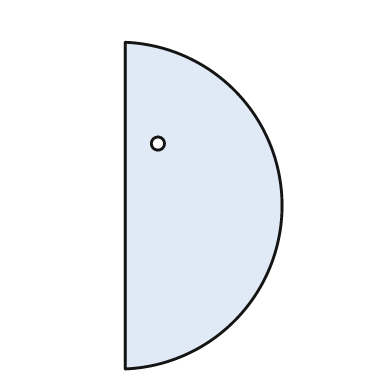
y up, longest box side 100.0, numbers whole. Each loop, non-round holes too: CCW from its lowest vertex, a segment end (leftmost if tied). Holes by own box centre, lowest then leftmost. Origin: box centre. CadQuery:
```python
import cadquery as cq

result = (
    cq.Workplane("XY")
    .moveTo(-24.0, -50.0)
    .threePointArc((24.0, 0.0), (-24.0, 50.0))
    .close()
    .moveTo(-14.0, 19.0)
    .circle(2.0)
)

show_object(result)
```